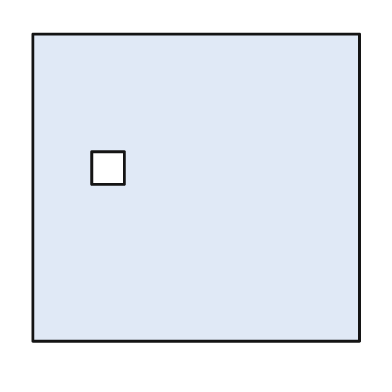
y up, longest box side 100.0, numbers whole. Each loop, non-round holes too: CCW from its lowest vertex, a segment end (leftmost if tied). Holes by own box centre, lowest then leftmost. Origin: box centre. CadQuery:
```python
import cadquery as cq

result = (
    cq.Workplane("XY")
    .moveTo(-50.0, -47.0)
    .lineTo(50.0, -47.0)
    .lineTo(50.0, 47.0)
    .lineTo(-50.0, 47.0)
    .close()
    .moveTo(-32.0, 1.0)
    .lineTo(-22.0, 1.0)
    .lineTo(-22.0, 11.0)
    .lineTo(-32.0, 11.0)
    .close()
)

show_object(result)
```